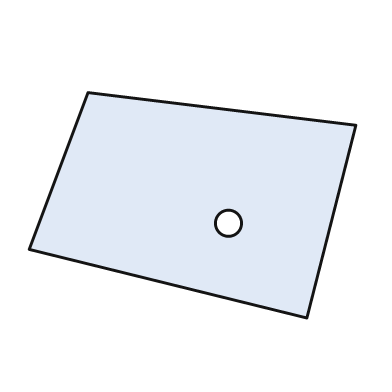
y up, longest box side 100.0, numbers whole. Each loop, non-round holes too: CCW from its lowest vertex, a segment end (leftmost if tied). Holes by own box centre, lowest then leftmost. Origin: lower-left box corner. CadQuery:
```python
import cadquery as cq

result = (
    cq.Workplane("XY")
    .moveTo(85.0, 0.0)
    .lineTo(100.0, 59.0)
    .lineTo(18.0, 69.0)
    .lineTo(0.0, 21.0)
    .close()
    .moveTo(61.0, 29.0)
    .circle(4.0)
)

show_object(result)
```